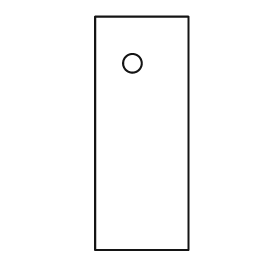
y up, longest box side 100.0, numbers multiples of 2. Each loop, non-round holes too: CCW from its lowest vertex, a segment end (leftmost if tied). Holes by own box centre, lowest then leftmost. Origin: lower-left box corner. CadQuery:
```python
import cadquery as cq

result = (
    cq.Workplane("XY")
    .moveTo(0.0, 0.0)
    .lineTo(40.0, 0.0)
    .lineTo(40.0, 100.0)
    .lineTo(0.0, 100.0)
    .close()
    .moveTo(16.0, 80.0)
    .circle(4.0)
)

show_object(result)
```